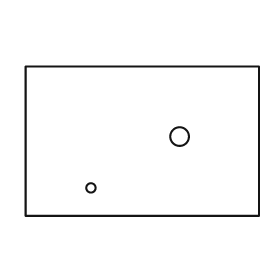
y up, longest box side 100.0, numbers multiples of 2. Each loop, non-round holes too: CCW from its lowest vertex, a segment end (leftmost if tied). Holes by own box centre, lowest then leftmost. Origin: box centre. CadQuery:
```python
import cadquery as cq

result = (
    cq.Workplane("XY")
    .moveTo(-50.0, -32.0)
    .lineTo(50.0, -32.0)
    .lineTo(50.0, 32.0)
    .lineTo(-50.0, 32.0)
    .close()
    .moveTo(-22.0, -20.0)
    .circle(2.0)
    .moveTo(16.0, 2.0)
    .circle(4.0)
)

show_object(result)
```